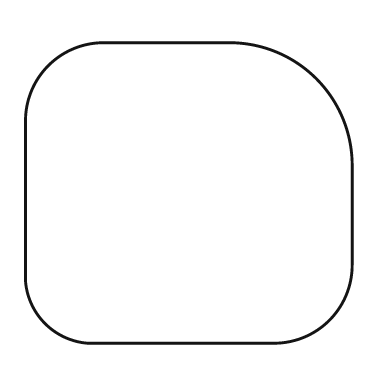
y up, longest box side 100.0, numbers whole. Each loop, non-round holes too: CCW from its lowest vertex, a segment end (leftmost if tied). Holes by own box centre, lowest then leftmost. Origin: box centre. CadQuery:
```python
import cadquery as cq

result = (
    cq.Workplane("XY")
    .moveTo(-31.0, -46.0)
    .lineTo(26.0, -46.0)
    .threePointArc((43.0, -39.0), (50.0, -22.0))
    .lineTo(50.0, 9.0)
    .threePointArc((39.0, 35.0), (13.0, 46.0))
    .lineTo(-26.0, 46.0)
    .threePointArc((-43.0, 39.0), (-50.0, 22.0))
    .lineTo(-50.0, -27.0)
    .threePointArc((-44.0, -40.0), (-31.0, -46.0))
    .close()
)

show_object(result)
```